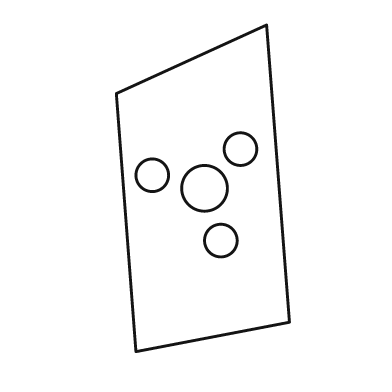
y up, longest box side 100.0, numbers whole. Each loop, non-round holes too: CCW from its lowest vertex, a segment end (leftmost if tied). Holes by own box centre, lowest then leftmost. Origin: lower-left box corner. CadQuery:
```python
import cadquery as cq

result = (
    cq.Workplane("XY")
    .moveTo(6.0, 0.0)
    .lineTo(53.0, 9.0)
    .lineTo(46.0, 100.0)
    .lineTo(0.0, 79.0)
    .close()
    .moveTo(32.0, 34.0)
    .circle(5.0)
    .moveTo(27.0, 50.0)
    .circle(7.0)
    .moveTo(11.0, 54.0)
    .circle(5.0)
    .moveTo(38.0, 62.0)
    .circle(5.0)
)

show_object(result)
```